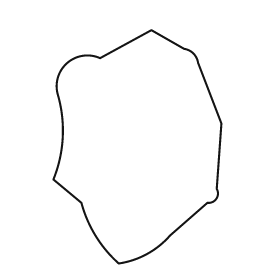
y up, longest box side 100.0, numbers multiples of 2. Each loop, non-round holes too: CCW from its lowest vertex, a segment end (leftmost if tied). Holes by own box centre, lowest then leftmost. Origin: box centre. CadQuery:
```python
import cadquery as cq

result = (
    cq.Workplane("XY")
    .moveTo(-8.0, -50.0)
    .threePointArc((4.0, -46.0), (14.0, -38.0))
    .lineTo(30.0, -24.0)
    .threePointArc((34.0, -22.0), (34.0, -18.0))
    .lineTo(36.0, 10.0)
    .lineTo(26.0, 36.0)
    .threePointArc((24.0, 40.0), (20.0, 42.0))
    .lineTo(6.0, 50.0)
    .lineTo(-16.0, 38.0)
    .threePointArc((-30.0, 36.0), (-34.0, 22.0))
    .threePointArc((-32.0, 4.0), (-36.0, -14.0))
    .lineTo(-24.0, -24.0)
    .threePointArc((-18.0, -38.0), (-8.0, -50.0))
    .close()
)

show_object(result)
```